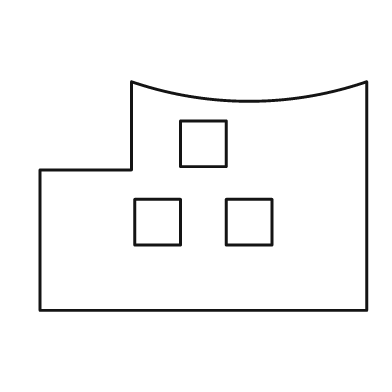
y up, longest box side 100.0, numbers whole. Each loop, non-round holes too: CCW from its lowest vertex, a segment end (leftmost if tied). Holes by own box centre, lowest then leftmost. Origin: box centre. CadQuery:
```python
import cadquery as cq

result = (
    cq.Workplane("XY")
    .moveTo(-50.0, -35.0)
    .lineTo(50.0, -35.0)
    .lineTo(50.0, 35.0)
    .threePointArc((14.0, 29.0), (-22.0, 35.0))
    .lineTo(-22.0, 8.0)
    .lineTo(-50.0, 8.0)
    .close()
    .moveTo(-21.0, -15.0)
    .lineTo(-7.0, -15.0)
    .lineTo(-7.0, -1.0)
    .lineTo(-21.0, -1.0)
    .close()
    .moveTo(7.0, -15.0)
    .lineTo(21.0, -15.0)
    .lineTo(21.0, -1.0)
    .lineTo(7.0, -1.0)
    .close()
    .moveTo(-7.0, 9.0)
    .lineTo(7.0, 9.0)
    .lineTo(7.0, 23.0)
    .lineTo(-7.0, 23.0)
    .close()
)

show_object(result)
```